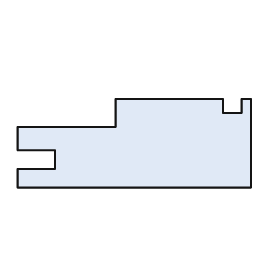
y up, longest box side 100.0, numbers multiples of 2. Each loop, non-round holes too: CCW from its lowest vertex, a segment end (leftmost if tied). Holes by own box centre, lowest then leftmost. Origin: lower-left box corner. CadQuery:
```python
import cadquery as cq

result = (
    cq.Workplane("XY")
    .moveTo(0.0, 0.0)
    .lineTo(100.0, 0.0)
    .lineTo(100.0, 38.0)
    .lineTo(96.0, 38.0)
    .lineTo(96.0, 32.0)
    .lineTo(88.0, 32.0)
    .lineTo(88.0, 38.0)
    .lineTo(42.0, 38.0)
    .lineTo(42.0, 26.0)
    .lineTo(0.0, 26.0)
    .lineTo(0.0, 16.0)
    .lineTo(16.0, 16.0)
    .lineTo(16.0, 8.0)
    .lineTo(0.0, 8.0)
    .close()
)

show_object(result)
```